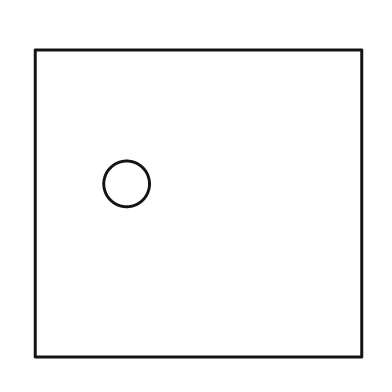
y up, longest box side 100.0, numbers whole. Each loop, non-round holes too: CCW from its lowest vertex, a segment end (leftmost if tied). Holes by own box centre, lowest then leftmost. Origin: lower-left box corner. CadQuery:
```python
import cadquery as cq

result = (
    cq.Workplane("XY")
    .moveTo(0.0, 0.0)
    .lineTo(100.0, 0.0)
    .lineTo(100.0, 94.0)
    .lineTo(0.0, 94.0)
    .close()
    .moveTo(28.0, 53.0)
    .circle(7.0)
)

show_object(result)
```